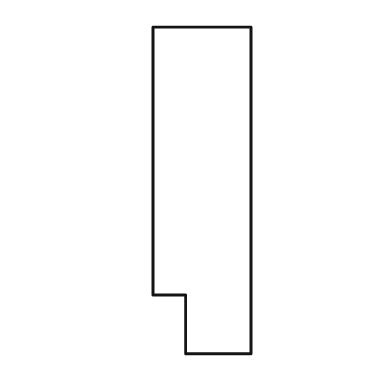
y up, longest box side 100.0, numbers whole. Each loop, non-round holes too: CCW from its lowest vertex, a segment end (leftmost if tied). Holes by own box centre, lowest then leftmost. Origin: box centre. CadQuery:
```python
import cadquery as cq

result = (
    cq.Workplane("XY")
    .moveTo(-5.0, -50.0)
    .lineTo(15.0, -50.0)
    .lineTo(15.0, 50.0)
    .lineTo(-15.0, 50.0)
    .lineTo(-15.0, -32.0)
    .lineTo(-5.0, -32.0)
    .close()
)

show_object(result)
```